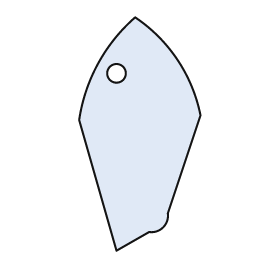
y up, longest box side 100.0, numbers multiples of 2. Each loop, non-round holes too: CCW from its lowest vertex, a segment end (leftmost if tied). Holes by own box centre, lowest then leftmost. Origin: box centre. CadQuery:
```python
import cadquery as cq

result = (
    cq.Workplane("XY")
    .moveTo(-10.0, -50.0)
    .lineTo(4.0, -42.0)
    .threePointArc((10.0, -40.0), (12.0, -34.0))
    .lineTo(26.0, 8.0)
    .threePointArc((16.0, 32.0), (-2.0, 50.0))
    .threePointArc((-18.0, 30.0), (-26.0, 6.0))
    .close()
    .moveTo(-10.0, 26.0)
    .circle(4.0)
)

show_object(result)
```